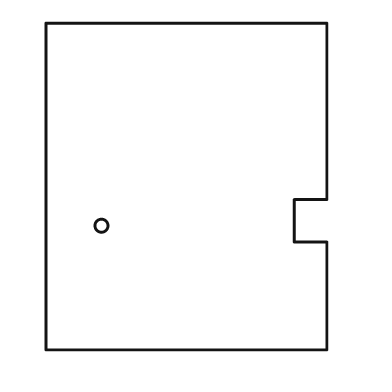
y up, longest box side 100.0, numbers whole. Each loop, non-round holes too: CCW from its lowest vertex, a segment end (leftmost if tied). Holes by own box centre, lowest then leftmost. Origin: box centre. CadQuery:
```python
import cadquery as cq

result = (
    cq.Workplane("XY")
    .moveTo(-43.0, -50.0)
    .lineTo(43.0, -50.0)
    .lineTo(43.0, -17.0)
    .lineTo(33.0, -17.0)
    .lineTo(33.0, -4.0)
    .lineTo(43.0, -4.0)
    .lineTo(43.0, 50.0)
    .lineTo(-43.0, 50.0)
    .close()
    .moveTo(-26.0, -12.0)
    .circle(2.0)
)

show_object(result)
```